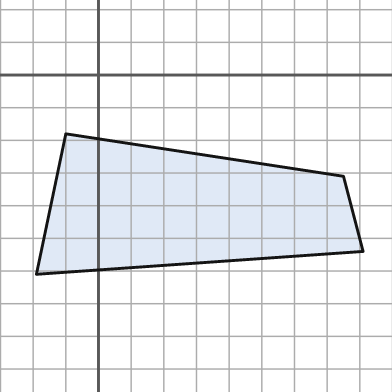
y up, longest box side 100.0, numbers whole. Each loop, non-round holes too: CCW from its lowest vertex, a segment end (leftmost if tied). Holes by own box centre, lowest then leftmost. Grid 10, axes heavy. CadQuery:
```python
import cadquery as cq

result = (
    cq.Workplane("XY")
    .moveTo(-19.0, -61.0)
    .lineTo(81.0, -54.0)
    .lineTo(75.0, -31.0)
    .lineTo(-10.0, -18.0)
    .close()
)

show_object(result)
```